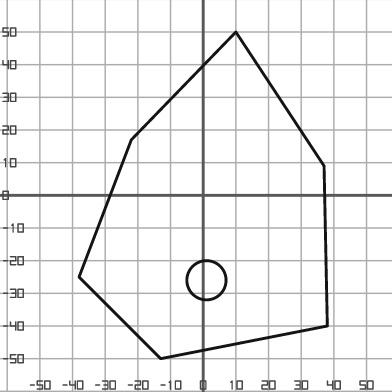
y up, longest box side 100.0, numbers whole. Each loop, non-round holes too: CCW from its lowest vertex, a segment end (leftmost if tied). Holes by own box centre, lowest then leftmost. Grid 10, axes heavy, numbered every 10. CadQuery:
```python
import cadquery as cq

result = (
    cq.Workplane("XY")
    .moveTo(-13.0, -50.0)
    .lineTo(38.0, -40.0)
    .lineTo(37.0, 9.0)
    .lineTo(10.0, 50.0)
    .lineTo(-22.0, 17.0)
    .lineTo(-38.0, -25.0)
    .close()
    .moveTo(1.0, -26.0)
    .circle(6.0)
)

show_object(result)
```